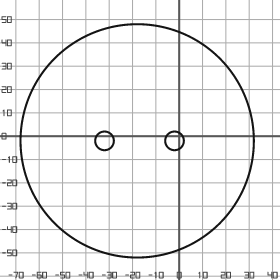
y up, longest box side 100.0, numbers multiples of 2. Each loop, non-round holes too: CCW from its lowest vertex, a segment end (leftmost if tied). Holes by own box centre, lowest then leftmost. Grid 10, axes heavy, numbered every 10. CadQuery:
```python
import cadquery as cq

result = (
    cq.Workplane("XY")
    .moveTo(-18.0, -2.0)
    .circle(50.0)
    .moveTo(-32.0, -2.0)
    .circle(4.0)
    .moveTo(-2.0, -2.0)
    .circle(4.0)
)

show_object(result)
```